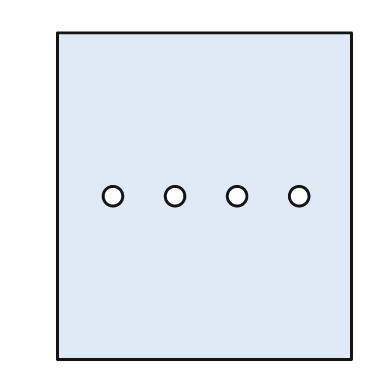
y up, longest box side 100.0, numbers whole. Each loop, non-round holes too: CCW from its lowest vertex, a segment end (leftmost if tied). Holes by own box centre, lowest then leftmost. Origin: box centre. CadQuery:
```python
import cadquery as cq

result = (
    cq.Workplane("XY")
    .moveTo(-45.0, -50.0)
    .lineTo(45.0, -50.0)
    .lineTo(45.0, 50.0)
    .lineTo(-45.0, 50.0)
    .close()
    .moveTo(-28.0, 0.0)
    .circle(3.0)
    .moveTo(-9.0, 0.0)
    .circle(3.0)
    .moveTo(10.0, 0.0)
    .circle(3.0)
    .moveTo(29.0, 0.0)
    .circle(3.0)
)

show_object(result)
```